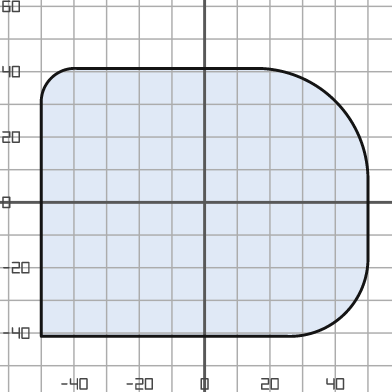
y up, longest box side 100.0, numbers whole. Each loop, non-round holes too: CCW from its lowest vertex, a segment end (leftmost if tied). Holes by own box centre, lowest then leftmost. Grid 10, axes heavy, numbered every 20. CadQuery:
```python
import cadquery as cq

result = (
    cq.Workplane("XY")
    .moveTo(-50.0, -41.0)
    .lineTo(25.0, -41.0)
    .threePointArc((43.0, -34.0), (50.0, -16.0))
    .lineTo(50.0, 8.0)
    .threePointArc((40.0, 31.0), (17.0, 41.0))
    .lineTo(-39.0, 41.0)
    .threePointArc((-47.0, 38.0), (-50.0, 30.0))
    .close()
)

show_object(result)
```